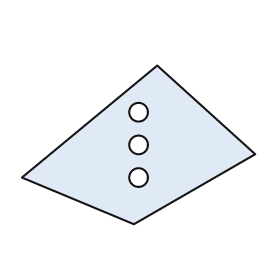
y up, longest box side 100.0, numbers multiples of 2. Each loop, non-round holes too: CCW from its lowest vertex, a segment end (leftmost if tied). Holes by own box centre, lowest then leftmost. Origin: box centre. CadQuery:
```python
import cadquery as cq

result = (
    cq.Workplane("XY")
    .moveTo(-2.0, -34.0)
    .lineTo(50.0, -4.0)
    .lineTo(8.0, 34.0)
    .lineTo(-50.0, -14.0)
    .close()
    .moveTo(0.0, -14.0)
    .circle(4.0)
    .moveTo(0.0, 0.0)
    .circle(4.0)
    .moveTo(0.0, 14.0)
    .circle(4.0)
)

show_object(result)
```